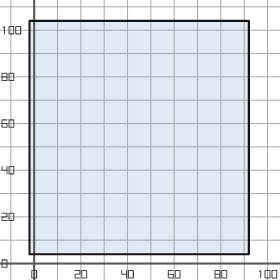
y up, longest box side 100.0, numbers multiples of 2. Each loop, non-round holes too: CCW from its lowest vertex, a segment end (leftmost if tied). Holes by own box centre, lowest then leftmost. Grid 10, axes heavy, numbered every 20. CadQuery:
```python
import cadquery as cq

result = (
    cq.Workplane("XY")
    .moveTo(-2.0, 4.0)
    .lineTo(92.0, 4.0)
    .lineTo(92.0, 104.0)
    .lineTo(-2.0, 104.0)
    .close()
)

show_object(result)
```